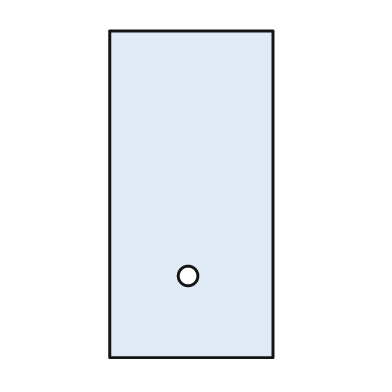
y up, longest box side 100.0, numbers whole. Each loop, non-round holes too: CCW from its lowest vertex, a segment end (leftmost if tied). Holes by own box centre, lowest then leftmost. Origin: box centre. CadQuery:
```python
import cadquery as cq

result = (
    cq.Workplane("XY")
    .moveTo(-25.0, -50.0)
    .lineTo(25.0, -50.0)
    .lineTo(25.0, 50.0)
    .lineTo(-25.0, 50.0)
    .close()
    .moveTo(-1.0, -25.0)
    .circle(3.0)
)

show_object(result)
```